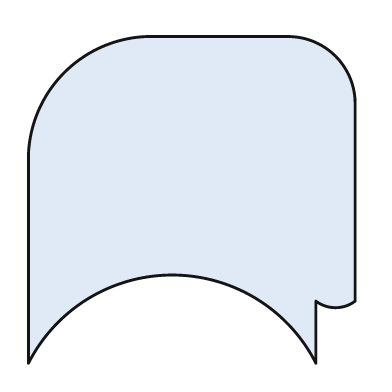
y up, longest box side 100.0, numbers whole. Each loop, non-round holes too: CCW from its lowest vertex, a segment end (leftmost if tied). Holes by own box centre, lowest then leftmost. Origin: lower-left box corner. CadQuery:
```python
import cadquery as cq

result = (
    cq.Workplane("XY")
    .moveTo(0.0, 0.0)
    .threePointArc((44.0, 27.0), (88.0, 0.0))
    .lineTo(88.0, 19.0)
    .threePointArc((94.0, 17.0), (100.0, 19.0))
    .lineTo(100.0, 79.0)
    .threePointArc((94.0, 94.0), (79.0, 100.0))
    .lineTo(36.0, 100.0)
    .threePointArc((11.0, 89.0), (0.0, 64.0))
    .close()
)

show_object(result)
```